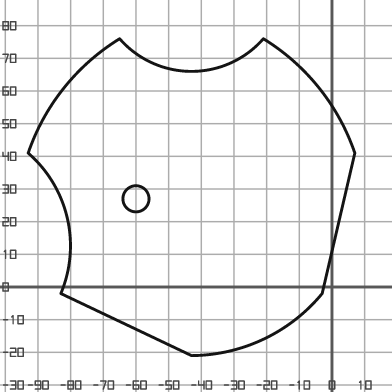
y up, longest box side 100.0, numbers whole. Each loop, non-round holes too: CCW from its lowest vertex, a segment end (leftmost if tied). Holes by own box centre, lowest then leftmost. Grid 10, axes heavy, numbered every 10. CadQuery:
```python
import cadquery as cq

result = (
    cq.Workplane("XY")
    .moveTo(-43.0, -21.0)
    .threePointArc((-21.0, -16.0), (-3.0, -2.0))
    .lineTo(7.0, 41.0)
    .threePointArc((-4.0, 61.0), (-21.0, 76.0))
    .threePointArc((-43.0, 66.0), (-65.0, 76.0))
    .threePointArc((-82.0, 61.0), (-93.0, 41.0))
    .threePointArc((-81.0, 21.0), (-83.0, -2.0))
    .close()
    .moveTo(-60.0, 27.0)
    .circle(4.0)
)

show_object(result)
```